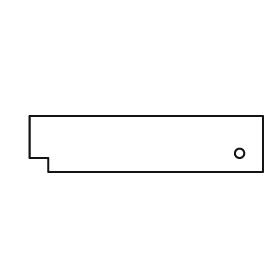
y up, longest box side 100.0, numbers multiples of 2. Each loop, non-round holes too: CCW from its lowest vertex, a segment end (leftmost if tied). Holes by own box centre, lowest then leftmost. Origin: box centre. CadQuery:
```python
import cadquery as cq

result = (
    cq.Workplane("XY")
    .moveTo(-42.0, -12.0)
    .lineTo(50.0, -12.0)
    .lineTo(50.0, 12.0)
    .lineTo(-50.0, 12.0)
    .lineTo(-50.0, -6.0)
    .lineTo(-42.0, -6.0)
    .close()
    .moveTo(40.0, -4.0)
    .circle(2.0)
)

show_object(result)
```